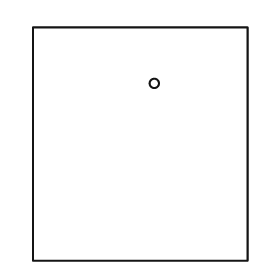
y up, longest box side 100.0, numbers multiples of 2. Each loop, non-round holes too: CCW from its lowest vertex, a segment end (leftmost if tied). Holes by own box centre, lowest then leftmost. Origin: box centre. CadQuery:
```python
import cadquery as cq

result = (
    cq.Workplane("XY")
    .moveTo(-46.0, -50.0)
    .lineTo(46.0, -50.0)
    .lineTo(46.0, 50.0)
    .lineTo(-46.0, 50.0)
    .close()
    .moveTo(6.0, 26.0)
    .circle(2.0)
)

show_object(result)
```